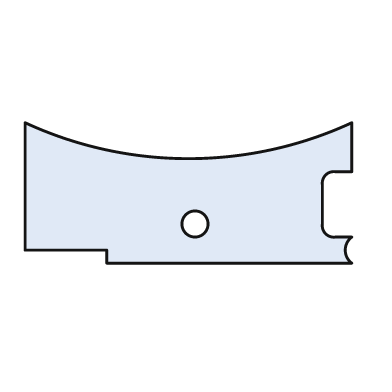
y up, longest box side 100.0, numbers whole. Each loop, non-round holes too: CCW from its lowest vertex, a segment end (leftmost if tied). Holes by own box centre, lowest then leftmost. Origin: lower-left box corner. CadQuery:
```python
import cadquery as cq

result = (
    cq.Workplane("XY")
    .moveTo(25.0, 0.0)
    .lineTo(100.0, 0.0)
    .threePointArc((98.0, 4.0), (100.0, 8.0))
    .lineTo(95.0, 8.0)
    .threePointArc((92.0, 9.0), (91.0, 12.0))
    .lineTo(91.0, 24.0)
    .threePointArc((92.0, 27.0), (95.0, 28.0))
    .lineTo(100.0, 28.0)
    .lineTo(100.0, 43.0)
    .threePointArc((50.0, 32.0), (0.0, 43.0))
    .lineTo(0.0, 4.0)
    .lineTo(25.0, 4.0)
    .close()
    .moveTo(52.0, 12.0)
    .circle(4.0)
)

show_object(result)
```